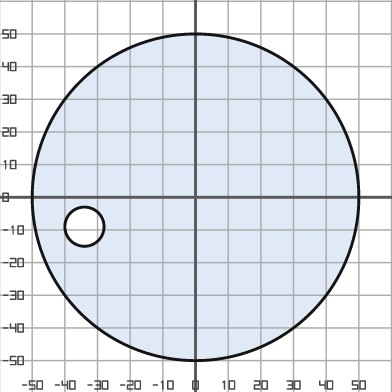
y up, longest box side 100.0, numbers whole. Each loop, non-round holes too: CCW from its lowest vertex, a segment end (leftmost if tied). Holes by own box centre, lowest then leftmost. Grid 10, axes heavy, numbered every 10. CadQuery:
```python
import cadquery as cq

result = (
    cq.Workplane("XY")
    .moveTo(0.0, 0.0)
    .circle(50.0)
    .moveTo(-34.0, -9.0)
    .circle(6.0)
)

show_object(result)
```